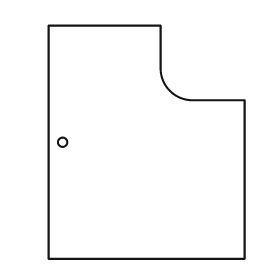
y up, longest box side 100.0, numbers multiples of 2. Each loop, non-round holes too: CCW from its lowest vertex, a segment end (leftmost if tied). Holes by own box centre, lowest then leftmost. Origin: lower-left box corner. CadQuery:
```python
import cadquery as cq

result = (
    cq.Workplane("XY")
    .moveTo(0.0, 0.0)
    .lineTo(84.0, 0.0)
    .lineTo(84.0, 68.0)
    .lineTo(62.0, 68.0)
    .threePointArc((52.0, 72.0), (48.0, 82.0))
    .lineTo(48.0, 100.0)
    .lineTo(0.0, 100.0)
    .close()
    .moveTo(6.0, 50.0)
    .circle(2.0)
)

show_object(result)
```